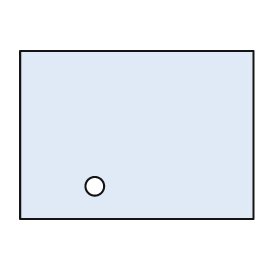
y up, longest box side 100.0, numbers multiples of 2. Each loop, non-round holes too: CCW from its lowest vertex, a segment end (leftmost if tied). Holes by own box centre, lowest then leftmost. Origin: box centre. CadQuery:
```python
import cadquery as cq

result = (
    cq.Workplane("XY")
    .moveTo(-50.0, -36.0)
    .lineTo(50.0, -36.0)
    .lineTo(50.0, 36.0)
    .lineTo(-50.0, 36.0)
    .close()
    .moveTo(-18.0, -22.0)
    .circle(4.0)
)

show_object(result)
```